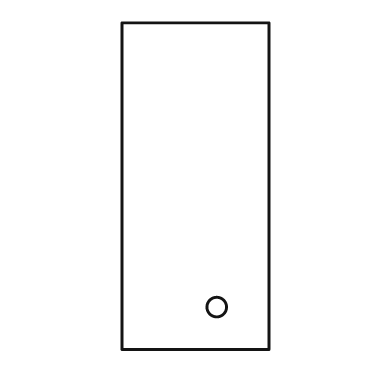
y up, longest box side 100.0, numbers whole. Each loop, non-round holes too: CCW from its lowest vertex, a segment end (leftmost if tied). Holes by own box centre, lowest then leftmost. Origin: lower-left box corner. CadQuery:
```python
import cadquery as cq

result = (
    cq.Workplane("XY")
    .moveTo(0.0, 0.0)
    .lineTo(45.0, 0.0)
    .lineTo(45.0, 100.0)
    .lineTo(0.0, 100.0)
    .close()
    .moveTo(29.0, 13.0)
    .circle(3.0)
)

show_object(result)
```